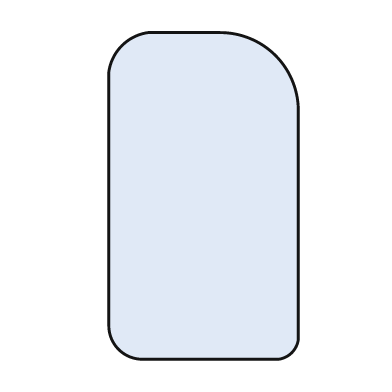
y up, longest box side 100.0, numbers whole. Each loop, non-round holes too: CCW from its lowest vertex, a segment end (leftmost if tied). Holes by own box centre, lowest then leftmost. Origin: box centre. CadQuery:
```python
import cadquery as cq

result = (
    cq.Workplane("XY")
    .moveTo(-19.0, -50.0)
    .lineTo(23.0, -50.0)
    .threePointArc((27.0, -48.0), (29.0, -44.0))
    .lineTo(29.0, 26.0)
    .threePointArc((22.0, 43.0), (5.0, 50.0))
    .lineTo(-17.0, 50.0)
    .threePointArc((-25.0, 46.0), (-29.0, 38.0))
    .lineTo(-29.0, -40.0)
    .threePointArc((-26.0, -47.0), (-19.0, -50.0))
    .close()
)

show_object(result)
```